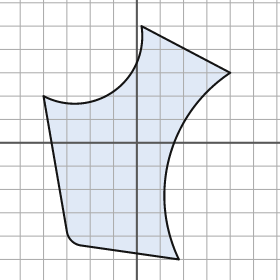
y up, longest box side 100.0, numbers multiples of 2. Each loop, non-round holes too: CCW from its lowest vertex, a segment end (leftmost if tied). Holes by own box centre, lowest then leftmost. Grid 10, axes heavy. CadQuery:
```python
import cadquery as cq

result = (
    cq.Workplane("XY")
    .moveTo(18.0, -50.0)
    .threePointArc((14.0, -6.0), (40.0, 30.0))
    .lineTo(2.0, 50.0)
    .threePointArc((-10.0, 22.0), (-40.0, 20.0))
    .lineTo(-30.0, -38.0)
    .threePointArc((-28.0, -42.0), (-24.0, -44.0))
    .close()
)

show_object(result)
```